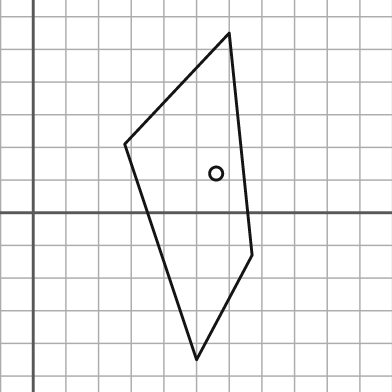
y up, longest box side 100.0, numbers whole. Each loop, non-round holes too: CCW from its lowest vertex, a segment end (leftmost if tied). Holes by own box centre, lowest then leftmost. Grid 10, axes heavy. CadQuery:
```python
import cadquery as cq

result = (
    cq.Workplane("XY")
    .moveTo(50.0, -45.0)
    .lineTo(67.0, -13.0)
    .lineTo(60.0, 55.0)
    .lineTo(28.0, 21.0)
    .close()
    .moveTo(56.0, 12.0)
    .circle(2.0)
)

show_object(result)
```